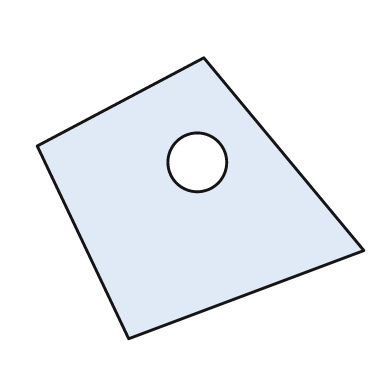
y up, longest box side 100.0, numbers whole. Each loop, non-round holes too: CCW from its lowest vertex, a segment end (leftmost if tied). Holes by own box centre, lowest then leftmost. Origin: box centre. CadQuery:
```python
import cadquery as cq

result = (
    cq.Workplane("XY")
    .moveTo(-22.0, -43.0)
    .lineTo(50.0, -16.0)
    .lineTo(1.0, 43.0)
    .lineTo(-50.0, 16.0)
    .close()
    .moveTo(-1.0, 11.0)
    .circle(9.0)
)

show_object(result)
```